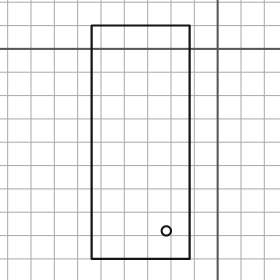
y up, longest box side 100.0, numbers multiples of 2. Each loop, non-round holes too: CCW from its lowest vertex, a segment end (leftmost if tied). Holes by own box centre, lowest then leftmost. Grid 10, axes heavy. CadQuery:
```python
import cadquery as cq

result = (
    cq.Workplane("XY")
    .moveTo(-54.0, -90.0)
    .lineTo(-12.0, -90.0)
    .lineTo(-12.0, 10.0)
    .lineTo(-54.0, 10.0)
    .close()
    .moveTo(-22.0, -78.0)
    .circle(2.0)
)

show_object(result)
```